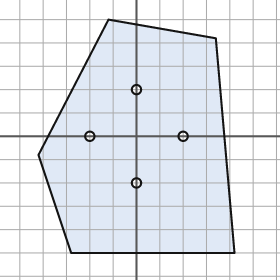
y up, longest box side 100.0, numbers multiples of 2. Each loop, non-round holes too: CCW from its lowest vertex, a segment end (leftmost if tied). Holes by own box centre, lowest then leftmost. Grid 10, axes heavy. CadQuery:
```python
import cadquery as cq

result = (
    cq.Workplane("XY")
    .moveTo(-28.0, -50.0)
    .lineTo(42.0, -50.0)
    .lineTo(34.0, 42.0)
    .lineTo(-12.0, 50.0)
    .lineTo(-42.0, -8.0)
    .close()
    .moveTo(0.0, -20.0)
    .circle(2.0)
    .moveTo(-20.0, 0.0)
    .circle(2.0)
    .moveTo(20.0, 0.0)
    .circle(2.0)
    .moveTo(0.0, 20.0)
    .circle(2.0)
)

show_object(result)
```